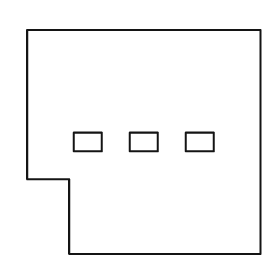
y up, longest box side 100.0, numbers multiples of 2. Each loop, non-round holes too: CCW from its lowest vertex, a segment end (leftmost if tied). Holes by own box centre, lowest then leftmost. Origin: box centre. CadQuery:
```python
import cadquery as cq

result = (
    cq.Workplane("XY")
    .moveTo(-32.0, -48.0)
    .lineTo(50.0, -48.0)
    .lineTo(50.0, 48.0)
    .lineTo(-50.0, 48.0)
    .lineTo(-50.0, -16.0)
    .lineTo(-32.0, -16.0)
    .close()
    .moveTo(-30.0, -4.0)
    .lineTo(-18.0, -4.0)
    .lineTo(-18.0, 4.0)
    .lineTo(-30.0, 4.0)
    .close()
    .moveTo(-6.0, -4.0)
    .lineTo(6.0, -4.0)
    .lineTo(6.0, 4.0)
    .lineTo(-6.0, 4.0)
    .close()
    .moveTo(18.0, -4.0)
    .lineTo(30.0, -4.0)
    .lineTo(30.0, 4.0)
    .lineTo(18.0, 4.0)
    .close()
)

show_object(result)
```